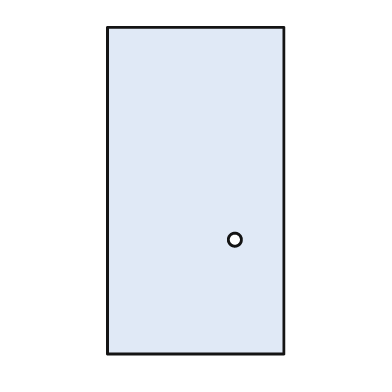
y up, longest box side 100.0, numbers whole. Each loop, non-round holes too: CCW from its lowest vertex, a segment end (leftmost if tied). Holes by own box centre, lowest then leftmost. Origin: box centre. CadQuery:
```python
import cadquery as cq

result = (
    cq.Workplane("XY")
    .moveTo(-27.0, -50.0)
    .lineTo(27.0, -50.0)
    .lineTo(27.0, 50.0)
    .lineTo(-27.0, 50.0)
    .close()
    .moveTo(12.0, -15.0)
    .circle(2.0)
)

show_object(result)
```